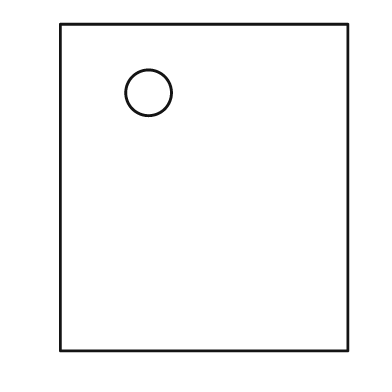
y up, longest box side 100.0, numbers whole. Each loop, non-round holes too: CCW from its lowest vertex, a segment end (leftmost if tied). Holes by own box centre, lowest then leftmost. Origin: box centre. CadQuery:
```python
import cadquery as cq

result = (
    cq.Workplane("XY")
    .moveTo(-44.0, -50.0)
    .lineTo(44.0, -50.0)
    .lineTo(44.0, 50.0)
    .lineTo(-44.0, 50.0)
    .close()
    .moveTo(-17.0, 29.0)
    .circle(7.0)
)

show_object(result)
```